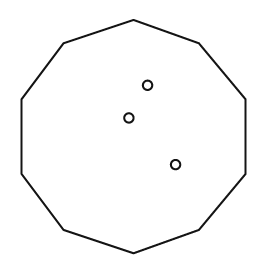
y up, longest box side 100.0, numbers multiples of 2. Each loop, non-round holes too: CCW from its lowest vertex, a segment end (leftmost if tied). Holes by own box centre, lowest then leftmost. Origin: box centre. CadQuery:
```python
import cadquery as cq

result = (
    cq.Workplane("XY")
    .moveTo(0.0, -50.0)
    .lineTo(28.0, -40.0)
    .lineTo(48.0, -16.0)
    .lineTo(48.0, 16.0)
    .lineTo(28.0, 40.0)
    .lineTo(0.0, 50.0)
    .lineTo(-30.0, 40.0)
    .lineTo(-48.0, 16.0)
    .lineTo(-48.0, -16.0)
    .lineTo(-30.0, -40.0)
    .close()
    .moveTo(18.0, -12.0)
    .circle(2.0)
    .moveTo(-2.0, 8.0)
    .circle(2.0)
    .moveTo(6.0, 22.0)
    .circle(2.0)
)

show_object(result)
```